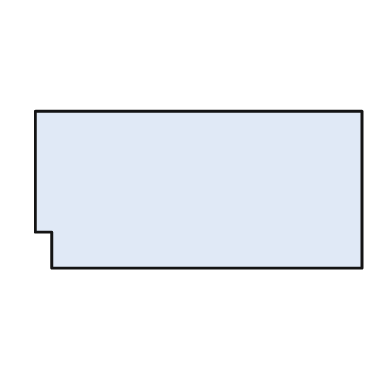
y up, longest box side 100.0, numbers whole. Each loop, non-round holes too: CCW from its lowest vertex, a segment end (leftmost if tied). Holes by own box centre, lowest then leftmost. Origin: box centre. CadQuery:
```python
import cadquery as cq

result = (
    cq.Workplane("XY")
    .moveTo(-45.0, -24.0)
    .lineTo(50.0, -24.0)
    .lineTo(50.0, 24.0)
    .lineTo(-50.0, 24.0)
    .lineTo(-50.0, -13.0)
    .lineTo(-45.0, -13.0)
    .close()
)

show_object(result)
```